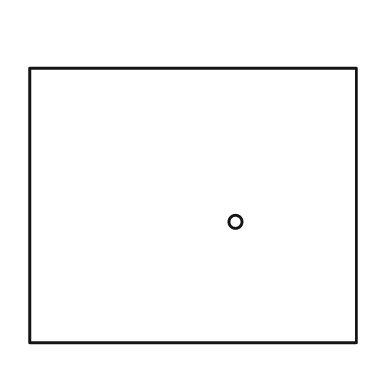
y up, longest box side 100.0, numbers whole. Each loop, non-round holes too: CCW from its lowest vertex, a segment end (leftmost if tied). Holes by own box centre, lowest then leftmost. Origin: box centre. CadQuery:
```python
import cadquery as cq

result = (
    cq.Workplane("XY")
    .moveTo(-50.0, -42.0)
    .lineTo(50.0, -42.0)
    .lineTo(50.0, 42.0)
    .lineTo(-50.0, 42.0)
    .close()
    .moveTo(13.0, -5.0)
    .circle(2.0)
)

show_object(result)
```